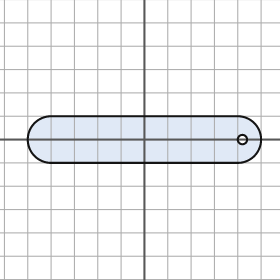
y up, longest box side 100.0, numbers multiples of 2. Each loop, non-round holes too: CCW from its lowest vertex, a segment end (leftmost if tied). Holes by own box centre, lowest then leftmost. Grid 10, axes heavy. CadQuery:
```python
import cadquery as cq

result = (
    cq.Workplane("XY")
    .moveTo(-40.0, -10.0)
    .lineTo(40.0, -10.0)
    .threePointArc((50.0, 0.0), (40.0, 10.0))
    .lineTo(-40.0, 10.0)
    .threePointArc((-50.0, 0.0), (-40.0, -10.0))
    .close()
    .moveTo(42.0, 0.0)
    .circle(2.0)
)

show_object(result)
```